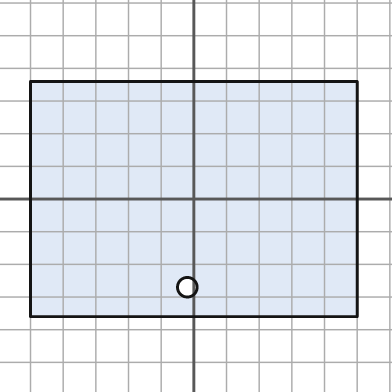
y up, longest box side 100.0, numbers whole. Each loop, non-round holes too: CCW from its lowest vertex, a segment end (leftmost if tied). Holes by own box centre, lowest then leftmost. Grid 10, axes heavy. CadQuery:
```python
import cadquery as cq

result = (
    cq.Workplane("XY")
    .moveTo(-50.0, -36.0)
    .lineTo(50.0, -36.0)
    .lineTo(50.0, 36.0)
    .lineTo(-50.0, 36.0)
    .close()
    .moveTo(-2.0, -27.0)
    .circle(3.0)
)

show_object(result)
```